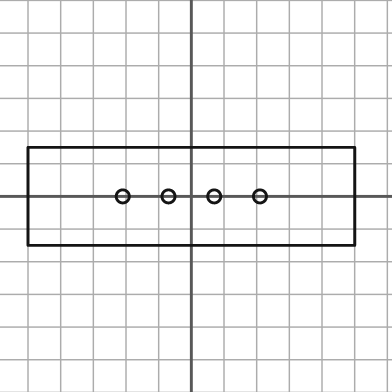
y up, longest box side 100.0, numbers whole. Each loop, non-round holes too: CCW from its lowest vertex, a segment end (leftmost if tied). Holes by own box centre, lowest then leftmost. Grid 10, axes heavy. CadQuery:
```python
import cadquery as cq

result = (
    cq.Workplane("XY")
    .moveTo(-50.0, -15.0)
    .lineTo(50.0, -15.0)
    .lineTo(50.0, 15.0)
    .lineTo(-50.0, 15.0)
    .close()
    .moveTo(-21.0, 0.0)
    .circle(2.0)
    .moveTo(-7.0, 0.0)
    .circle(2.0)
    .moveTo(7.0, 0.0)
    .circle(2.0)
    .moveTo(21.0, 0.0)
    .circle(2.0)
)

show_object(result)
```